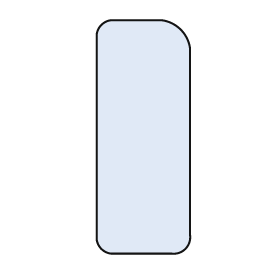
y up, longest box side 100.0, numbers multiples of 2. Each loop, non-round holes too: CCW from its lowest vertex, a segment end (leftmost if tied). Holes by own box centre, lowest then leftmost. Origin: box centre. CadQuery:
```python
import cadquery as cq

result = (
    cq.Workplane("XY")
    .moveTo(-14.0, -50.0)
    .lineTo(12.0, -50.0)
    .threePointArc((18.0, -48.0), (20.0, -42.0))
    .lineTo(20.0, 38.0)
    .threePointArc((16.0, 46.0), (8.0, 50.0))
    .lineTo(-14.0, 50.0)
    .threePointArc((-18.0, 48.0), (-20.0, 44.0))
    .lineTo(-20.0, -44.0)
    .threePointArc((-18.0, -48.0), (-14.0, -50.0))
    .close()
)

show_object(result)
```